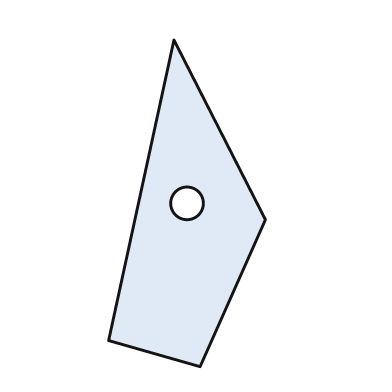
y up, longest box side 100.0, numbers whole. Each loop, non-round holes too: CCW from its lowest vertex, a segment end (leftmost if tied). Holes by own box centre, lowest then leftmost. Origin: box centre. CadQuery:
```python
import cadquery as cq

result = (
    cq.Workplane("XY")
    .moveTo(4.0, -50.0)
    .lineTo(24.0, -5.0)
    .lineTo(-4.0, 50.0)
    .lineTo(-24.0, -42.0)
    .close()
    .moveTo(0.0, 0.0)
    .circle(5.0)
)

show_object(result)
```